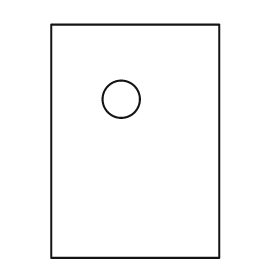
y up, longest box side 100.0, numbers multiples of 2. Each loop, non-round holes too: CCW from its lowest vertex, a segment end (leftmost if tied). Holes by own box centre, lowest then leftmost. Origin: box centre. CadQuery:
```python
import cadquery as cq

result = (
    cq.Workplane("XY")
    .moveTo(-36.0, -50.0)
    .lineTo(36.0, -50.0)
    .lineTo(36.0, 50.0)
    .lineTo(-36.0, 50.0)
    .close()
    .moveTo(-6.0, 18.0)
    .circle(8.0)
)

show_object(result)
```